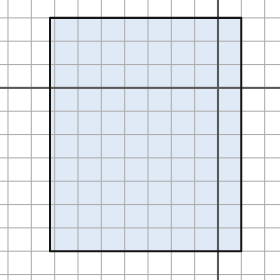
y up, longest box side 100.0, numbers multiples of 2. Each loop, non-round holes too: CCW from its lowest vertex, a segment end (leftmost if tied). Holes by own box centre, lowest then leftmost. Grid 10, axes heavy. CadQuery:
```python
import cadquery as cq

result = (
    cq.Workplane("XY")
    .moveTo(-72.0, -70.0)
    .lineTo(10.0, -70.0)
    .lineTo(10.0, 30.0)
    .lineTo(-72.0, 30.0)
    .close()
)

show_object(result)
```